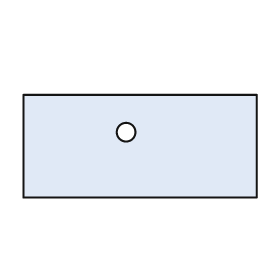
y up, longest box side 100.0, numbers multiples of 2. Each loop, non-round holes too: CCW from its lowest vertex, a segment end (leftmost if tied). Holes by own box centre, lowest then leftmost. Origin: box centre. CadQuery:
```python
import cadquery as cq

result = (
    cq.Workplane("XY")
    .moveTo(-50.0, -22.0)
    .lineTo(50.0, -22.0)
    .lineTo(50.0, 22.0)
    .lineTo(-50.0, 22.0)
    .close()
    .moveTo(-6.0, 6.0)
    .circle(4.0)
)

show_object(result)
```